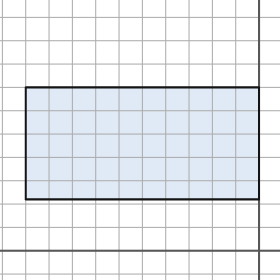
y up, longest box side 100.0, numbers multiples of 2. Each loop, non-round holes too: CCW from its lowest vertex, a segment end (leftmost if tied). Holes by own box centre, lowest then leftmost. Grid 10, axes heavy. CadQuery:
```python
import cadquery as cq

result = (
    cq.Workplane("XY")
    .moveTo(-100.0, 22.0)
    .lineTo(0.0, 22.0)
    .lineTo(0.0, 70.0)
    .lineTo(-100.0, 70.0)
    .close()
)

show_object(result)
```